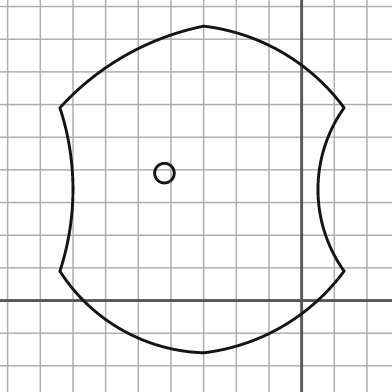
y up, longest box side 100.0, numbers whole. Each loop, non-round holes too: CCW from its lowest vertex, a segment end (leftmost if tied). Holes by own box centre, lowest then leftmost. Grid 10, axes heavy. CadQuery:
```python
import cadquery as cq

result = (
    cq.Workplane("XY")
    .moveTo(-30.0, -16.0)
    .threePointArc((-6.0, -8.0), (13.0, 9.0))
    .threePointArc((5.0, 34.0), (13.0, 59.0))
    .threePointArc((-6.0, 76.0), (-30.0, 84.0))
    .threePointArc((-54.0, 75.0), (-74.0, 59.0))
    .threePointArc((-70.0, 34.0), (-74.0, 9.0))
    .threePointArc((-55.0, -9.0), (-30.0, -16.0))
    .close()
    .moveTo(-42.0, 39.0)
    .circle(3.0)
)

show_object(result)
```